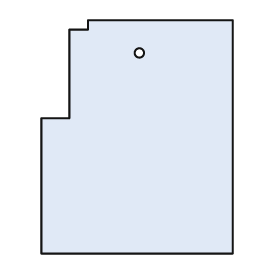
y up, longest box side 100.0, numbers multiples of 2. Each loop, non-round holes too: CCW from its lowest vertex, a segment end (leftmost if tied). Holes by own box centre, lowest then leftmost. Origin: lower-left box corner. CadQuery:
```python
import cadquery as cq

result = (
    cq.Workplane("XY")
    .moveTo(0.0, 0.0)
    .lineTo(82.0, 0.0)
    .lineTo(82.0, 100.0)
    .lineTo(20.0, 100.0)
    .lineTo(20.0, 96.0)
    .lineTo(12.0, 96.0)
    .lineTo(12.0, 58.0)
    .lineTo(0.0, 58.0)
    .close()
    .moveTo(42.0, 86.0)
    .circle(2.0)
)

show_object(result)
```